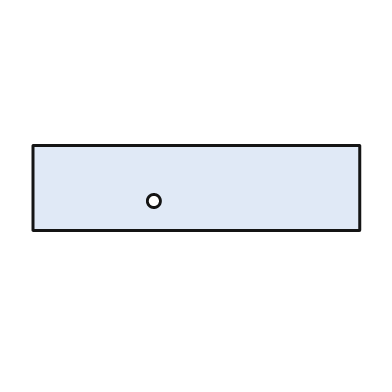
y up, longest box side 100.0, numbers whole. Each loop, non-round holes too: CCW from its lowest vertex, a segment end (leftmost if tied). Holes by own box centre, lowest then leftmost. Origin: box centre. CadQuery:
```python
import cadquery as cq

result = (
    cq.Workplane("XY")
    .moveTo(-50.0, -13.0)
    .lineTo(50.0, -13.0)
    .lineTo(50.0, 13.0)
    .lineTo(-50.0, 13.0)
    .close()
    .moveTo(-13.0, -4.0)
    .circle(2.0)
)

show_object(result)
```